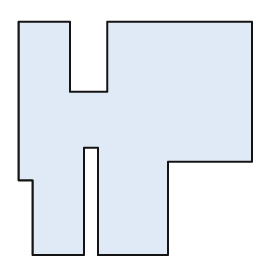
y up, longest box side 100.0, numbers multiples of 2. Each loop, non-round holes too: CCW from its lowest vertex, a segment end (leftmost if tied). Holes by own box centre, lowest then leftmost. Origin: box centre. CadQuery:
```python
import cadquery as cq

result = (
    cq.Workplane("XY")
    .moveTo(-44.0, -50.0)
    .lineTo(-22.0, -50.0)
    .lineTo(-22.0, -4.0)
    .lineTo(-16.0, -4.0)
    .lineTo(-16.0, -50.0)
    .lineTo(14.0, -50.0)
    .lineTo(14.0, -10.0)
    .lineTo(50.0, -10.0)
    .lineTo(50.0, 50.0)
    .lineTo(-12.0, 50.0)
    .lineTo(-12.0, 20.0)
    .lineTo(-28.0, 20.0)
    .lineTo(-28.0, 50.0)
    .lineTo(-50.0, 50.0)
    .lineTo(-50.0, -18.0)
    .lineTo(-44.0, -18.0)
    .close()
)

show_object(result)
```